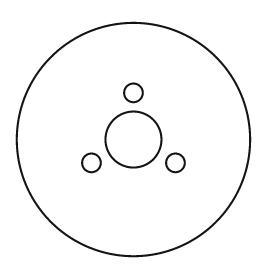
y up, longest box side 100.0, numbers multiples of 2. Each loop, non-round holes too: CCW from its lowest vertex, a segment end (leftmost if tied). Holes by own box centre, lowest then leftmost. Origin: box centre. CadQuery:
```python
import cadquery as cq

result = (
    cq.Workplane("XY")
    .moveTo(0.0, 0.0)
    .circle(50.0)
    .moveTo(-18.0, -10.0)
    .circle(4.0)
    .moveTo(18.0, -10.0)
    .circle(4.0)
    .moveTo(0.0, 0.0)
    .circle(12.0)
    .moveTo(0.0, 20.0)
    .circle(4.0)
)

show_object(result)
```